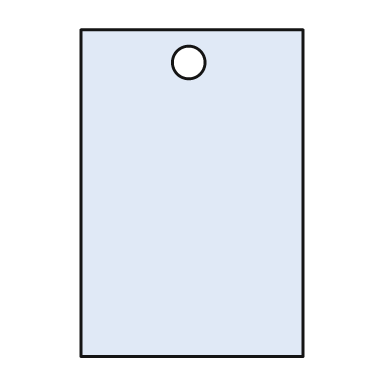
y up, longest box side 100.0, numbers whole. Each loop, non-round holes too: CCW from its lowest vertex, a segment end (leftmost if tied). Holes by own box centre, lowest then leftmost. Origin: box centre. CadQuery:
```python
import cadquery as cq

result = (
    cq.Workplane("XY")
    .moveTo(-34.0, -50.0)
    .lineTo(34.0, -50.0)
    .lineTo(34.0, 50.0)
    .lineTo(-34.0, 50.0)
    .close()
    .moveTo(-1.0, 40.0)
    .circle(5.0)
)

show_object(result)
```